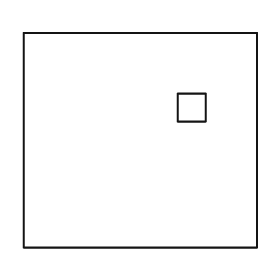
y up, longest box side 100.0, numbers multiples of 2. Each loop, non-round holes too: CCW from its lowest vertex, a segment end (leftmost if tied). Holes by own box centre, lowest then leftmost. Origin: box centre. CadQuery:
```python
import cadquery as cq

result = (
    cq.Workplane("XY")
    .moveTo(-50.0, -46.0)
    .lineTo(50.0, -46.0)
    .lineTo(50.0, 46.0)
    .lineTo(-50.0, 46.0)
    .close()
    .moveTo(16.0, 8.0)
    .lineTo(28.0, 8.0)
    .lineTo(28.0, 20.0)
    .lineTo(16.0, 20.0)
    .close()
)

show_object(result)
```